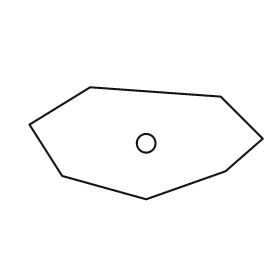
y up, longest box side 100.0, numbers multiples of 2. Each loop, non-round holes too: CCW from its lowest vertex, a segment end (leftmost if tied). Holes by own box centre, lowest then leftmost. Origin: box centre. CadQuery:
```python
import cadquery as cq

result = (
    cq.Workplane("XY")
    .moveTo(0.0, -24.0)
    .lineTo(34.0, -12.0)
    .lineTo(50.0, 2.0)
    .lineTo(32.0, 20.0)
    .lineTo(-24.0, 24.0)
    .lineTo(-50.0, 8.0)
    .lineTo(-36.0, -14.0)
    .close()
    .moveTo(0.0, 0.0)
    .circle(4.0)
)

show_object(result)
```